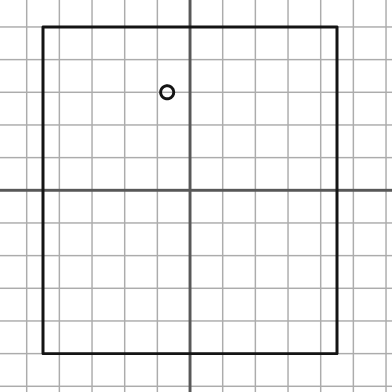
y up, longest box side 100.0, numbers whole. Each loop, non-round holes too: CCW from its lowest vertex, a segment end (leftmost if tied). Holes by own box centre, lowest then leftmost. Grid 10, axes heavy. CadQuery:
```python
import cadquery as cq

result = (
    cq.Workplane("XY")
    .moveTo(-45.0, -50.0)
    .lineTo(45.0, -50.0)
    .lineTo(45.0, 50.0)
    .lineTo(-45.0, 50.0)
    .close()
    .moveTo(-7.0, 30.0)
    .circle(2.0)
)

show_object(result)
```